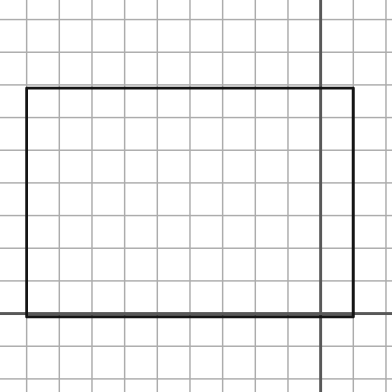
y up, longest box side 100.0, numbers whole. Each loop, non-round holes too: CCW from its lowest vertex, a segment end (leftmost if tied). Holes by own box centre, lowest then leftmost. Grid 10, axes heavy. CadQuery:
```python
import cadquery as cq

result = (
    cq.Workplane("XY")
    .moveTo(-90.0, -1.0)
    .lineTo(10.0, -1.0)
    .lineTo(10.0, 69.0)
    .lineTo(-90.0, 69.0)
    .close()
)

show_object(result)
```